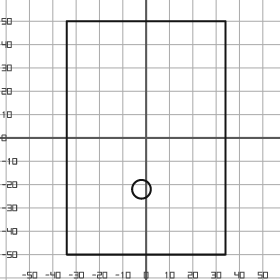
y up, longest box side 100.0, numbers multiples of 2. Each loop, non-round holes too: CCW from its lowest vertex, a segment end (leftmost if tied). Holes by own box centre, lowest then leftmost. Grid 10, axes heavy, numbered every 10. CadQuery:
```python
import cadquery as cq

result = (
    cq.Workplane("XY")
    .moveTo(-34.0, -50.0)
    .lineTo(34.0, -50.0)
    .lineTo(34.0, 50.0)
    .lineTo(-34.0, 50.0)
    .close()
    .moveTo(-2.0, -22.0)
    .circle(4.0)
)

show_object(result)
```